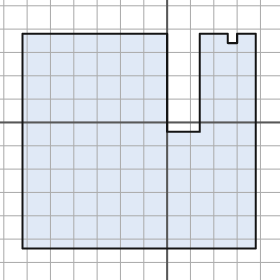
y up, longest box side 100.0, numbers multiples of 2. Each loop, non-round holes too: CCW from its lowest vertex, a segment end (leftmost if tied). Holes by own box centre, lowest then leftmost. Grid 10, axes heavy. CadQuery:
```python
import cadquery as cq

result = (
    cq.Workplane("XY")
    .moveTo(-62.0, -54.0)
    .lineTo(38.0, -54.0)
    .lineTo(38.0, 38.0)
    .lineTo(30.0, 38.0)
    .lineTo(30.0, 34.0)
    .lineTo(26.0, 34.0)
    .lineTo(26.0, 38.0)
    .lineTo(14.0, 38.0)
    .lineTo(14.0, -4.0)
    .lineTo(0.0, -4.0)
    .lineTo(0.0, 38.0)
    .lineTo(-62.0, 38.0)
    .close()
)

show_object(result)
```